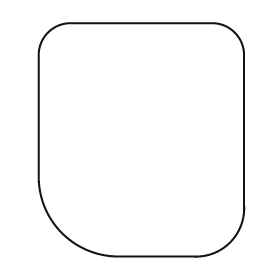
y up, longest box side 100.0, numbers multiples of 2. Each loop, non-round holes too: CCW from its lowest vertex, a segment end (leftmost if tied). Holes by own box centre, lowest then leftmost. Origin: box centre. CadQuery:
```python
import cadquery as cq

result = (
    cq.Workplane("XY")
    .moveTo(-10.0, -50.0)
    .lineTo(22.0, -50.0)
    .threePointArc((38.0, -44.0), (44.0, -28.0))
    .lineTo(44.0, 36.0)
    .threePointArc((40.0, 46.0), (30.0, 50.0))
    .lineTo(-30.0, 50.0)
    .threePointArc((-40.0, 46.0), (-44.0, 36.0))
    .lineTo(-44.0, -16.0)
    .threePointArc((-34.0, -40.0), (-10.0, -50.0))
    .close()
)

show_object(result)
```